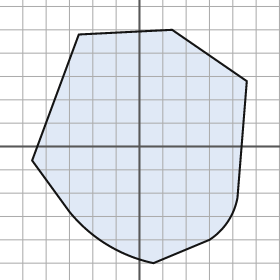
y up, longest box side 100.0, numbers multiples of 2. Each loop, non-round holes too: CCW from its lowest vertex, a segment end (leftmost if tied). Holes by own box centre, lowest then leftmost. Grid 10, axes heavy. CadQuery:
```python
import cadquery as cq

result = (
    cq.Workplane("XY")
    .moveTo(6.0, -50.0)
    .lineTo(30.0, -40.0)
    .threePointArc((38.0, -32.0), (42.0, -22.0))
    .lineTo(46.0, 28.0)
    .lineTo(14.0, 50.0)
    .lineTo(-26.0, 48.0)
    .lineTo(-46.0, -6.0)
    .lineTo(-30.0, -28.0)
    .threePointArc((-14.0, -42.0), (6.0, -50.0))
    .close()
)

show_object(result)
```